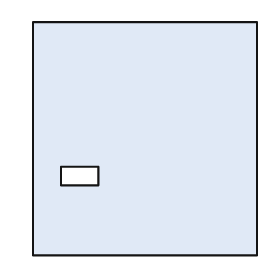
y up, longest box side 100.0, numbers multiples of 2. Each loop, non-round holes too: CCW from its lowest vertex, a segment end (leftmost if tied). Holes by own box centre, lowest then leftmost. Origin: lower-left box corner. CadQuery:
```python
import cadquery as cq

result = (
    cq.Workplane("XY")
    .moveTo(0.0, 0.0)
    .lineTo(96.0, 0.0)
    .lineTo(96.0, 100.0)
    .lineTo(0.0, 100.0)
    .close()
    .moveTo(12.0, 30.0)
    .lineTo(28.0, 30.0)
    .lineTo(28.0, 38.0)
    .lineTo(12.0, 38.0)
    .close()
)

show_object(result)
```